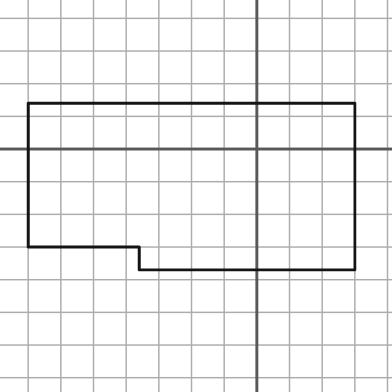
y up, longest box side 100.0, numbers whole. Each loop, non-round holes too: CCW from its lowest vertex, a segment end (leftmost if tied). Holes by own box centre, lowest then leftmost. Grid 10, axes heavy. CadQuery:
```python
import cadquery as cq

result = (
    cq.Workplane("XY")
    .moveTo(-36.0, -37.0)
    .lineTo(30.0, -37.0)
    .lineTo(30.0, 14.0)
    .lineTo(-70.0, 14.0)
    .lineTo(-70.0, -30.0)
    .lineTo(-36.0, -30.0)
    .close()
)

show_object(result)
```